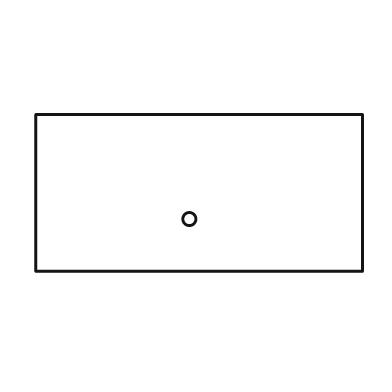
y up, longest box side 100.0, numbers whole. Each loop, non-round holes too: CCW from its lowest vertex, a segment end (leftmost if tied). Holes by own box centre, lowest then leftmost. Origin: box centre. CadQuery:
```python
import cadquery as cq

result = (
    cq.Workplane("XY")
    .moveTo(-50.0, -24.0)
    .lineTo(50.0, -24.0)
    .lineTo(50.0, 24.0)
    .lineTo(-50.0, 24.0)
    .close()
    .moveTo(-3.0, -8.0)
    .circle(2.0)
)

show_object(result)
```